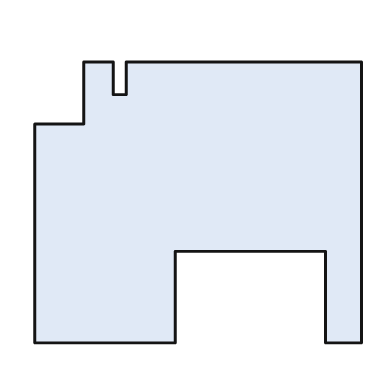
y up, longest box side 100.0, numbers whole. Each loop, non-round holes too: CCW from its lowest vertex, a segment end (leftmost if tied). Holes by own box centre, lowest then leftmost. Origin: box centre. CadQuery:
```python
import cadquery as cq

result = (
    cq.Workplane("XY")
    .moveTo(-50.0, -43.0)
    .lineTo(-7.0, -43.0)
    .lineTo(-7.0, -15.0)
    .lineTo(39.0, -15.0)
    .lineTo(39.0, -43.0)
    .lineTo(50.0, -43.0)
    .lineTo(50.0, 43.0)
    .lineTo(-22.0, 43.0)
    .lineTo(-22.0, 33.0)
    .lineTo(-26.0, 33.0)
    .lineTo(-26.0, 43.0)
    .lineTo(-35.0, 43.0)
    .lineTo(-35.0, 24.0)
    .lineTo(-50.0, 24.0)
    .close()
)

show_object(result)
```